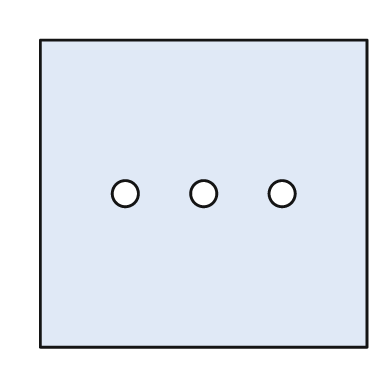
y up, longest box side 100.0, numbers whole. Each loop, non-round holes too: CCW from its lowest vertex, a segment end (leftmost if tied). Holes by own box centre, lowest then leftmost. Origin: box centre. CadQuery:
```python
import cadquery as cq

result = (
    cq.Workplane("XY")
    .moveTo(-50.0, -47.0)
    .lineTo(50.0, -47.0)
    .lineTo(50.0, 47.0)
    .lineTo(-50.0, 47.0)
    .close()
    .moveTo(-24.0, 0.0)
    .circle(4.0)
    .moveTo(0.0, 0.0)
    .circle(4.0)
    .moveTo(24.0, 0.0)
    .circle(4.0)
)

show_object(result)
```